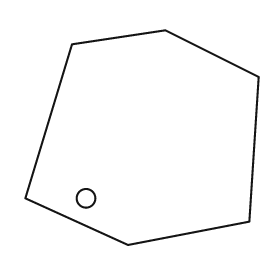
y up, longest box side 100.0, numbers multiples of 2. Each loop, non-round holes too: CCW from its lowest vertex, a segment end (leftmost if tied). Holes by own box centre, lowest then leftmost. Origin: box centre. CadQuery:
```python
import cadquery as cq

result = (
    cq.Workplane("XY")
    .moveTo(-6.0, -46.0)
    .lineTo(46.0, -36.0)
    .lineTo(50.0, 26.0)
    .lineTo(10.0, 46.0)
    .lineTo(-30.0, 40.0)
    .lineTo(-50.0, -26.0)
    .close()
    .moveTo(-24.0, -26.0)
    .circle(4.0)
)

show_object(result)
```